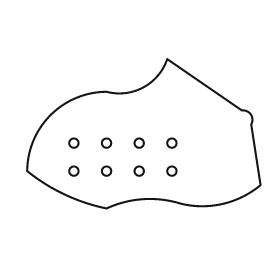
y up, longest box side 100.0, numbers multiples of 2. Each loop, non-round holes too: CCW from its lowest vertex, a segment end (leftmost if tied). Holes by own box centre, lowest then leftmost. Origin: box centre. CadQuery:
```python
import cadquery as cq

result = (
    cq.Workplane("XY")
    .moveTo(-16.0, -32.0)
    .threePointArc((0.0, -28.0), (16.0, -30.0))
    .threePointArc((34.0, -30.0), (50.0, -22.0))
    .lineTo(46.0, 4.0)
    .threePointArc((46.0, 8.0), (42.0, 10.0))
    .lineTo(10.0, 32.0)
    .threePointArc((0.0, 20.0), (-16.0, 18.0))
    .threePointArc((-40.0, 8.0), (-50.0, -16.0))
    .threePointArc((-34.0, -26.0), (-16.0, -32.0))
    .close()
    .moveTo(-30.0, -16.0)
    .circle(2.0)
    .moveTo(-16.0, -16.0)
    .circle(2.0)
    .moveTo(-2.0, -16.0)
    .circle(2.0)
    .moveTo(12.0, -16.0)
    .circle(2.0)
    .moveTo(-30.0, -4.0)
    .circle(2.0)
    .moveTo(-16.0, -4.0)
    .circle(2.0)
    .moveTo(-2.0, -4.0)
    .circle(2.0)
    .moveTo(12.0, -4.0)
    .circle(2.0)
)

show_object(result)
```